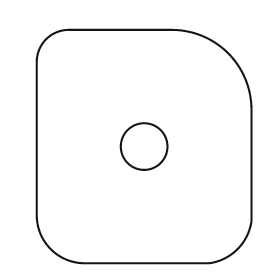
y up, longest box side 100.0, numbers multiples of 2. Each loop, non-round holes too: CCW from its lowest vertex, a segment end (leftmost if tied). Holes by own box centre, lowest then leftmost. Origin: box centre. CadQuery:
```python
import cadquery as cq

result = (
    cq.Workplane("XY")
    .moveTo(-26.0, -50.0)
    .lineTo(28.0, -50.0)
    .threePointArc((40.0, -44.0), (46.0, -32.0))
    .lineTo(46.0, 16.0)
    .threePointArc((36.0, 40.0), (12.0, 50.0))
    .lineTo(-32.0, 50.0)
    .threePointArc((-42.0, 46.0), (-46.0, 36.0))
    .lineTo(-46.0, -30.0)
    .threePointArc((-40.0, -44.0), (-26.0, -50.0))
    .close()
    .moveTo(0.0, 0.0)
    .circle(10.0)
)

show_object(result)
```